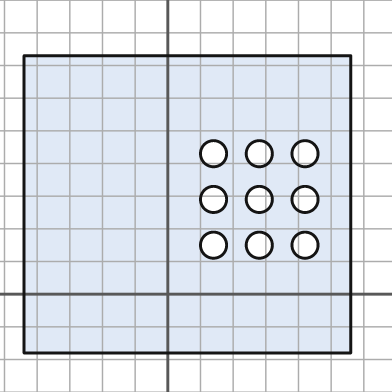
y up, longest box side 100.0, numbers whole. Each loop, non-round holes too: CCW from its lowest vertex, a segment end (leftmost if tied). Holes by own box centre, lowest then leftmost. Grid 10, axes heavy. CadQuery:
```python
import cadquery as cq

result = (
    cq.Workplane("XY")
    .moveTo(-44.0, -18.0)
    .lineTo(56.0, -18.0)
    .lineTo(56.0, 73.0)
    .lineTo(-44.0, 73.0)
    .close()
    .moveTo(14.0, 15.0)
    .circle(4.0)
    .moveTo(28.0, 15.0)
    .circle(4.0)
    .moveTo(42.0, 15.0)
    .circle(4.0)
    .moveTo(14.0, 29.0)
    .circle(4.0)
    .moveTo(28.0, 29.0)
    .circle(4.0)
    .moveTo(42.0, 29.0)
    .circle(4.0)
    .moveTo(14.0, 43.0)
    .circle(4.0)
    .moveTo(28.0, 43.0)
    .circle(4.0)
    .moveTo(42.0, 43.0)
    .circle(4.0)
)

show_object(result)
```